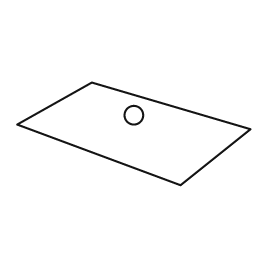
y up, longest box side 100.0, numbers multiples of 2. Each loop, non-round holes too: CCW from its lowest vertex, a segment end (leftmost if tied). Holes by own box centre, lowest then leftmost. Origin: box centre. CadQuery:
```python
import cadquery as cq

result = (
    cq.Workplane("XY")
    .moveTo(20.0, -22.0)
    .lineTo(50.0, 2.0)
    .lineTo(-18.0, 22.0)
    .lineTo(-50.0, 4.0)
    .close()
    .moveTo(0.0, 8.0)
    .circle(4.0)
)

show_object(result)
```